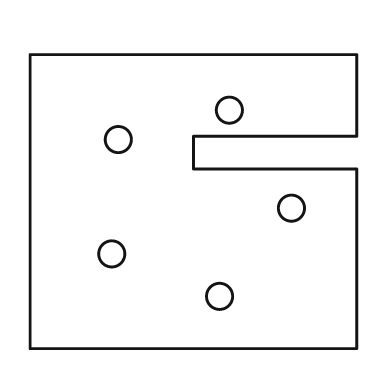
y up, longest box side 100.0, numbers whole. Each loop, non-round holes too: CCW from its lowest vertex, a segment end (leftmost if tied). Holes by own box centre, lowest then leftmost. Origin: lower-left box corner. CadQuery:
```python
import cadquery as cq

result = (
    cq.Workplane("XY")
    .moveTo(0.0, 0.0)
    .lineTo(100.0, 0.0)
    .lineTo(100.0, 55.0)
    .lineTo(50.0, 55.0)
    .lineTo(50.0, 65.0)
    .lineTo(100.0, 65.0)
    .lineTo(100.0, 90.0)
    .lineTo(0.0, 90.0)
    .close()
    .moveTo(58.0, 16.0)
    .circle(4.0)
    .moveTo(25.0, 29.0)
    .circle(4.0)
    .moveTo(80.0, 43.0)
    .circle(4.0)
    .moveTo(27.0, 64.0)
    .circle(4.0)
    .moveTo(61.0, 73.0)
    .circle(4.0)
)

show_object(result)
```